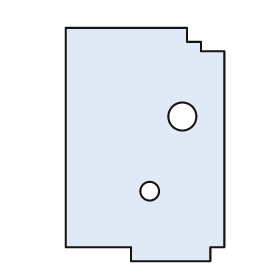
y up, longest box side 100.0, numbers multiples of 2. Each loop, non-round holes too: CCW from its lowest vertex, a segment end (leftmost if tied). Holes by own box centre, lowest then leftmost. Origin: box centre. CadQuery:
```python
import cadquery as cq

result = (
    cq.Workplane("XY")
    .moveTo(-6.0, -50.0)
    .lineTo(28.0, -50.0)
    .lineTo(28.0, -44.0)
    .lineTo(34.0, -44.0)
    .lineTo(34.0, 40.0)
    .lineTo(24.0, 40.0)
    .lineTo(24.0, 44.0)
    .lineTo(18.0, 44.0)
    .lineTo(18.0, 50.0)
    .lineTo(-34.0, 50.0)
    .lineTo(-34.0, -44.0)
    .lineTo(-6.0, -44.0)
    .close()
    .moveTo(2.0, -20.0)
    .circle(4.0)
    .moveTo(16.0, 12.0)
    .circle(6.0)
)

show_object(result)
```